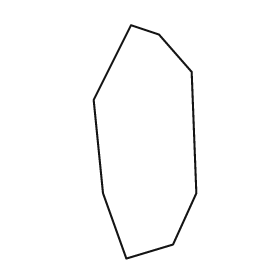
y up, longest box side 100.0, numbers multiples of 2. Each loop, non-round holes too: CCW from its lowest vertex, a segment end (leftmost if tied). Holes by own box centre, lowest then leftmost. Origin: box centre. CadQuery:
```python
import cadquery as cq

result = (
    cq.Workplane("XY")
    .moveTo(-8.0, -50.0)
    .lineTo(12.0, -44.0)
    .lineTo(22.0, -22.0)
    .lineTo(20.0, 30.0)
    .lineTo(6.0, 46.0)
    .lineTo(-6.0, 50.0)
    .lineTo(-22.0, 18.0)
    .lineTo(-18.0, -22.0)
    .close()
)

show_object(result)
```